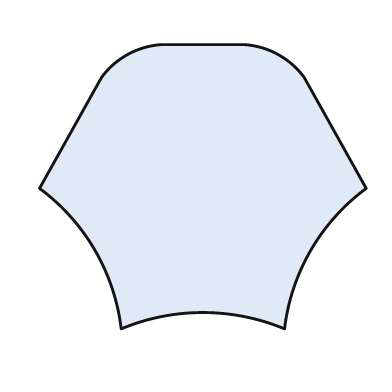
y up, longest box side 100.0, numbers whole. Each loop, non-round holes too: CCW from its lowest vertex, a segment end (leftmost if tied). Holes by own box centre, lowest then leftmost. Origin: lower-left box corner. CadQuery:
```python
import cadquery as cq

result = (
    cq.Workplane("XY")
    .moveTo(25.0, 0.0)
    .threePointArc((50.0, 5.0), (75.0, 0.0))
    .threePointArc((83.0, 24.0), (100.0, 43.0))
    .lineTo(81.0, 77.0)
    .threePointArc((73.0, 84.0), (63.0, 87.0))
    .lineTo(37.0, 87.0)
    .threePointArc((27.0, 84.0), (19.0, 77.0))
    .lineTo(0.0, 43.0)
    .threePointArc((17.0, 24.0), (25.0, 0.0))
    .close()
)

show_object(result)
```